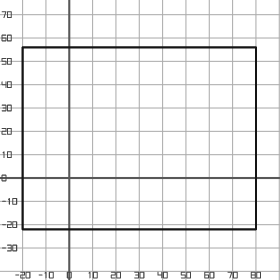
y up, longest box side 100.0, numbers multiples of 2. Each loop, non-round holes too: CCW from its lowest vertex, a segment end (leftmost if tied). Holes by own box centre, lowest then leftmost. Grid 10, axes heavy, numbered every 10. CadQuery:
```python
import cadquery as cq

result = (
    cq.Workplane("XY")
    .moveTo(-20.0, -22.0)
    .lineTo(80.0, -22.0)
    .lineTo(80.0, 56.0)
    .lineTo(-20.0, 56.0)
    .close()
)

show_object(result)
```